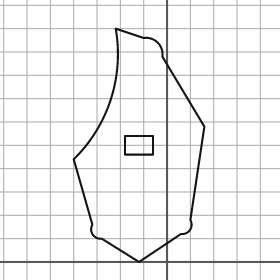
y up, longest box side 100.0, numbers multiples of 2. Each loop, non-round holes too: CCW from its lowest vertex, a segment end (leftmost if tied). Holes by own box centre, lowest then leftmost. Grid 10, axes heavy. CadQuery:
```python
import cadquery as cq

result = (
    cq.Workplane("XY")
    .moveTo(-12.0, 0.0)
    .lineTo(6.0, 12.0)
    .threePointArc((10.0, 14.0), (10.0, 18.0))
    .lineTo(16.0, 58.0)
    .lineTo(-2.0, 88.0)
    .threePointArc((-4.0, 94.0), (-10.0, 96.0))
    .lineTo(-22.0, 100.0)
    .threePointArc((-24.0, 70.0), (-40.0, 44.0))
    .lineTo(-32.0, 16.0)
    .threePointArc((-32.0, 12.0), (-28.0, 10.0))
    .close()
    .moveTo(-18.0, 46.0)
    .lineTo(-6.0, 46.0)
    .lineTo(-6.0, 54.0)
    .lineTo(-18.0, 54.0)
    .close()
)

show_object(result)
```